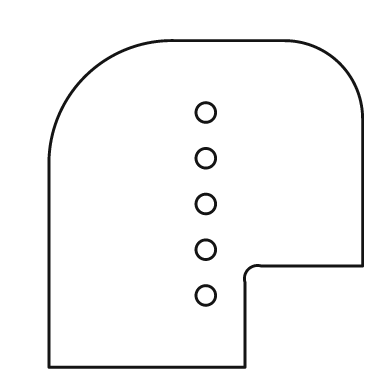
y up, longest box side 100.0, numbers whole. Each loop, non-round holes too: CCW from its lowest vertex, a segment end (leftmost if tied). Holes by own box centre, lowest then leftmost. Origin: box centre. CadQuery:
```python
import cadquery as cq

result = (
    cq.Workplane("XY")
    .moveTo(-48.0, -50.0)
    .lineTo(12.0, -50.0)
    .lineTo(12.0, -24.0)
    .threePointArc((13.0, -20.0), (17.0, -19.0))
    .lineTo(48.0, -19.0)
    .lineTo(48.0, 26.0)
    .threePointArc((41.0, 43.0), (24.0, 50.0))
    .lineTo(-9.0, 50.0)
    .threePointArc((-37.0, 39.0), (-48.0, 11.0))
    .close()
    .moveTo(0.0, -28.0)
    .circle(3.0)
    .moveTo(0.0, -14.0)
    .circle(3.0)
    .moveTo(0.0, 0.0)
    .circle(3.0)
    .moveTo(0.0, 14.0)
    .circle(3.0)
    .moveTo(0.0, 28.0)
    .circle(3.0)
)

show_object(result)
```